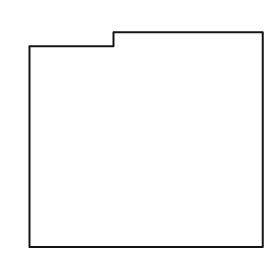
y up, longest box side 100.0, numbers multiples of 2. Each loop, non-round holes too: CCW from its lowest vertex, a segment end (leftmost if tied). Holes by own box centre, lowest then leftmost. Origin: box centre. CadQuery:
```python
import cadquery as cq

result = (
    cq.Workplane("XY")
    .moveTo(-50.0, -46.0)
    .lineTo(50.0, -46.0)
    .lineTo(50.0, 46.0)
    .lineTo(-14.0, 46.0)
    .lineTo(-14.0, 40.0)
    .lineTo(-50.0, 40.0)
    .close()
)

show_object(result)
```